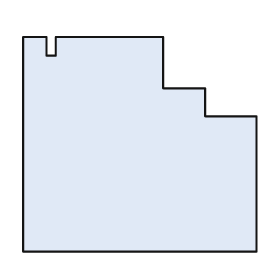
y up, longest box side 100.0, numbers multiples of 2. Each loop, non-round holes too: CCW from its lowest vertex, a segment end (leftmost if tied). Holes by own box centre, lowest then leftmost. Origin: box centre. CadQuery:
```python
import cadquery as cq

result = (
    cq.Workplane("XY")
    .moveTo(-50.0, -46.0)
    .lineTo(50.0, -46.0)
    .lineTo(50.0, 12.0)
    .lineTo(28.0, 12.0)
    .lineTo(28.0, 24.0)
    .lineTo(10.0, 24.0)
    .lineTo(10.0, 46.0)
    .lineTo(-36.0, 46.0)
    .lineTo(-36.0, 38.0)
    .lineTo(-40.0, 38.0)
    .lineTo(-40.0, 46.0)
    .lineTo(-50.0, 46.0)
    .close()
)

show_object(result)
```